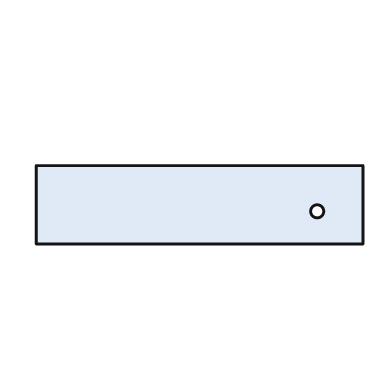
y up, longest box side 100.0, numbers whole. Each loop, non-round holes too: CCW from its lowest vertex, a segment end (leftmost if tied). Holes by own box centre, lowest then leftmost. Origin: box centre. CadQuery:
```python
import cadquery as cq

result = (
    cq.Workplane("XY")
    .moveTo(-50.0, -12.0)
    .lineTo(50.0, -12.0)
    .lineTo(50.0, 12.0)
    .lineTo(-50.0, 12.0)
    .close()
    .moveTo(36.0, -2.0)
    .circle(2.0)
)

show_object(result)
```